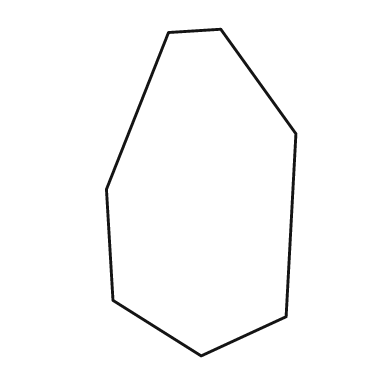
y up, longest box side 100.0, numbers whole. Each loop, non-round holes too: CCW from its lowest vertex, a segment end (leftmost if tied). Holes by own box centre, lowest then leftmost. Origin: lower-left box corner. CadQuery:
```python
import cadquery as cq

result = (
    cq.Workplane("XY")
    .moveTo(29.0, 0.0)
    .lineTo(55.0, 12.0)
    .lineTo(58.0, 68.0)
    .lineTo(35.0, 100.0)
    .lineTo(19.0, 99.0)
    .lineTo(0.0, 51.0)
    .lineTo(2.0, 17.0)
    .close()
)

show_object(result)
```